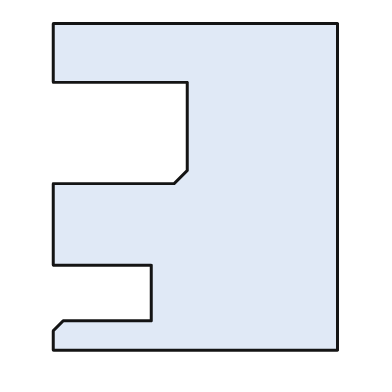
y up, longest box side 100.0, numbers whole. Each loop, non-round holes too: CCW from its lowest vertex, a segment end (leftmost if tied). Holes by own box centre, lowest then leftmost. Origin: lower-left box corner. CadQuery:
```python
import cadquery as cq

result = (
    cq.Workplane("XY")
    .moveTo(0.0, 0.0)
    .lineTo(87.0, 0.0)
    .lineTo(87.0, 100.0)
    .lineTo(0.0, 100.0)
    .lineTo(0.0, 82.0)
    .lineTo(41.0, 82.0)
    .lineTo(41.0, 55.0)
    .lineTo(37.0, 51.0)
    .lineTo(0.0, 51.0)
    .lineTo(0.0, 26.0)
    .lineTo(30.0, 26.0)
    .lineTo(30.0, 9.0)
    .lineTo(3.0, 9.0)
    .lineTo(0.0, 6.0)
    .close()
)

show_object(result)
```